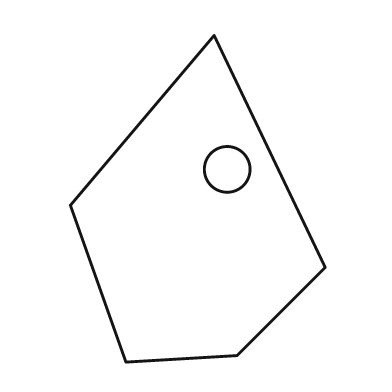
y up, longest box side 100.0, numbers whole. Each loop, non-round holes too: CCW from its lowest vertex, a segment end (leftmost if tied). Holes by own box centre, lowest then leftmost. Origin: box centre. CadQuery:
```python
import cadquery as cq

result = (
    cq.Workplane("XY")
    .moveTo(-22.0, -50.0)
    .lineTo(12.0, -48.0)
    .lineTo(39.0, -21.0)
    .lineTo(5.0, 50.0)
    .lineTo(-39.0, -2.0)
    .close()
    .moveTo(9.0, 9.0)
    .circle(7.0)
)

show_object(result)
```